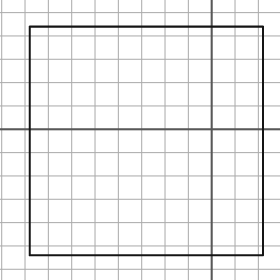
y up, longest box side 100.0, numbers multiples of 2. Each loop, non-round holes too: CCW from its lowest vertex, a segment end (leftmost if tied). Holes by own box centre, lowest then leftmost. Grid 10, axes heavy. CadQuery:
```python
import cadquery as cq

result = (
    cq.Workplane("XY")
    .moveTo(-78.0, -54.0)
    .lineTo(22.0, -54.0)
    .lineTo(22.0, 44.0)
    .lineTo(-78.0, 44.0)
    .close()
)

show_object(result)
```